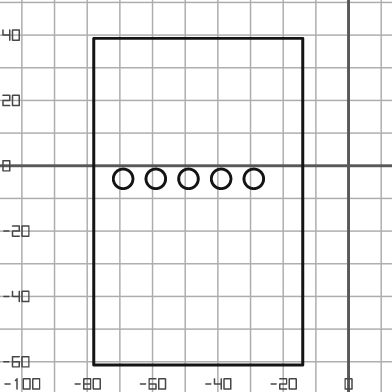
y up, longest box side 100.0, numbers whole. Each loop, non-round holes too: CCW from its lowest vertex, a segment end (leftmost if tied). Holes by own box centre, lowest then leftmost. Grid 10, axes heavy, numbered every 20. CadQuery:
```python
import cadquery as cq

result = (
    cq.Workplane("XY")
    .moveTo(-78.0, -61.0)
    .lineTo(-14.0, -61.0)
    .lineTo(-14.0, 39.0)
    .lineTo(-78.0, 39.0)
    .close()
    .moveTo(-69.0, -4.0)
    .circle(3.0)
    .moveTo(-59.0, -4.0)
    .circle(3.0)
    .moveTo(-49.0, -4.0)
    .circle(3.0)
    .moveTo(-39.0, -4.0)
    .circle(3.0)
    .moveTo(-29.0, -4.0)
    .circle(3.0)
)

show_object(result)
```